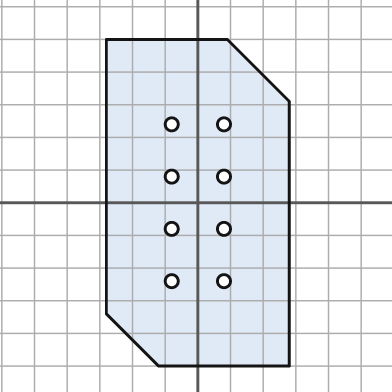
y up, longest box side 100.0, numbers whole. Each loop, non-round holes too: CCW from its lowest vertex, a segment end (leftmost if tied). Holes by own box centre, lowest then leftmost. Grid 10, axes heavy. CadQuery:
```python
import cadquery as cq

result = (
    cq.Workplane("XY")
    .moveTo(-12.0, -50.0)
    .lineTo(28.0, -50.0)
    .lineTo(28.0, 31.0)
    .lineTo(9.0, 50.0)
    .lineTo(-28.0, 50.0)
    .lineTo(-28.0, -34.0)
    .close()
    .moveTo(-8.0, -24.0)
    .circle(2.0)
    .moveTo(8.0, -24.0)
    .circle(2.0)
    .moveTo(-8.0, -8.0)
    .circle(2.0)
    .moveTo(8.0, -8.0)
    .circle(2.0)
    .moveTo(-8.0, 8.0)
    .circle(2.0)
    .moveTo(8.0, 8.0)
    .circle(2.0)
    .moveTo(-8.0, 24.0)
    .circle(2.0)
    .moveTo(8.0, 24.0)
    .circle(2.0)
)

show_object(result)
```